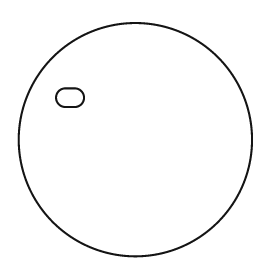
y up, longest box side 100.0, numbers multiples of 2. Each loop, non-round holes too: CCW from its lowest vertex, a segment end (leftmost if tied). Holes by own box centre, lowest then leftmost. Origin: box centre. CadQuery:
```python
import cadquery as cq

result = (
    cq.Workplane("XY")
    .moveTo(0.0, 0.0)
    .circle(50.0)
    .moveTo(-30.0, 14.0)
    .lineTo(-26.0, 14.0)
    .threePointArc((-22.0, 18.0), (-26.0, 22.0))
    .lineTo(-30.0, 22.0)
    .threePointArc((-34.0, 18.0), (-30.0, 14.0))
    .close()
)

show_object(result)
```